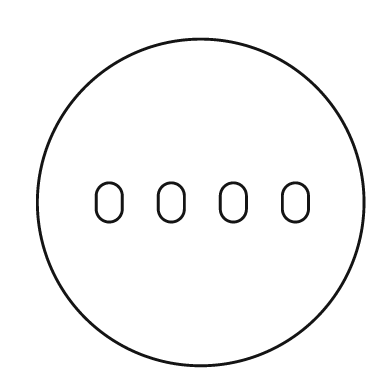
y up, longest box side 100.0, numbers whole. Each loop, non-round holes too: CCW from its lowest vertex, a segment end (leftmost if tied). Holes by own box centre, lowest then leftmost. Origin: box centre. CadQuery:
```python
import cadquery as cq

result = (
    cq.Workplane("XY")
    .moveTo(0.0, 0.0)
    .circle(50.0)
    .moveTo(-32.0, -2.0)
    .threePointArc((-28.0, -6.0), (-24.0, -2.0))
    .lineTo(-24.0, 2.0)
    .threePointArc((-28.0, 6.0), (-32.0, 2.0))
    .close()
    .moveTo(-13.0, -2.0)
    .threePointArc((-9.0, -6.0), (-5.0, -2.0))
    .lineTo(-5.0, 2.0)
    .threePointArc((-9.0, 6.0), (-13.0, 2.0))
    .close()
    .moveTo(6.0, -2.0)
    .threePointArc((10.0, -6.0), (14.0, -2.0))
    .lineTo(14.0, 2.0)
    .threePointArc((10.0, 6.0), (6.0, 2.0))
    .close()
    .moveTo(25.0, -2.0)
    .threePointArc((29.0, -6.0), (33.0, -2.0))
    .lineTo(33.0, 2.0)
    .threePointArc((29.0, 6.0), (25.0, 2.0))
    .close()
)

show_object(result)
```